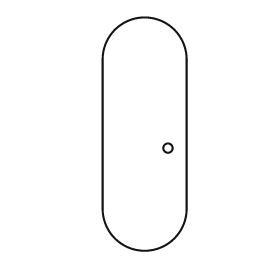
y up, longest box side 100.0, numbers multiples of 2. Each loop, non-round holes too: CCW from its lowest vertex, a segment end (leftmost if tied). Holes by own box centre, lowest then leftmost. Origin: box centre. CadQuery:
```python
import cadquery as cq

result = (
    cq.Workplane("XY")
    .moveTo(-18.0, -32.0)
    .threePointArc((0.0, -50.0), (18.0, -32.0))
    .lineTo(18.0, 32.0)
    .threePointArc((0.0, 50.0), (-18.0, 32.0))
    .close()
    .moveTo(10.0, -6.0)
    .circle(2.0)
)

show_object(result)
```